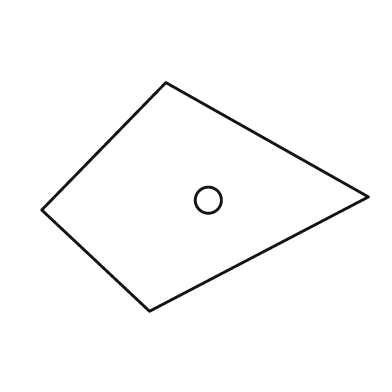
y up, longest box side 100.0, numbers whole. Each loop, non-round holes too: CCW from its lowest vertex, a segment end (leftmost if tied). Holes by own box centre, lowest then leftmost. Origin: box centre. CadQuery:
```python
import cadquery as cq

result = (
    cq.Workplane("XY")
    .moveTo(-17.0, -35.0)
    .lineTo(50.0, 0.0)
    .lineTo(-12.0, 35.0)
    .lineTo(-50.0, -4.0)
    .close()
    .moveTo(1.0, -1.0)
    .circle(4.0)
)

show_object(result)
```